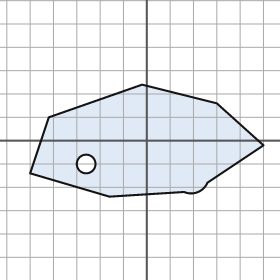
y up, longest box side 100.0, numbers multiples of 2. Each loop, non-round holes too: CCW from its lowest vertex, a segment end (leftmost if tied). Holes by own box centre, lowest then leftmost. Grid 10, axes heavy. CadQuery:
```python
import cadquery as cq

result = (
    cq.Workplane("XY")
    .moveTo(-16.0, -24.0)
    .lineTo(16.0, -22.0)
    .threePointArc((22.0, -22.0), (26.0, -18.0))
    .lineTo(50.0, -2.0)
    .lineTo(30.0, 16.0)
    .lineTo(-2.0, 24.0)
    .lineTo(-42.0, 10.0)
    .lineTo(-50.0, -14.0)
    .close()
    .moveTo(-26.0, -10.0)
    .circle(4.0)
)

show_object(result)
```